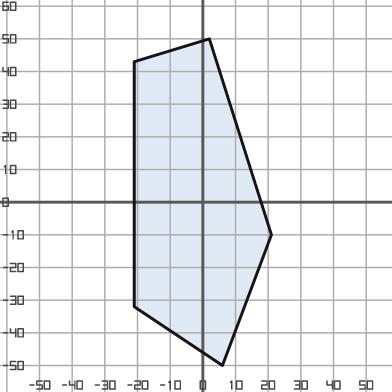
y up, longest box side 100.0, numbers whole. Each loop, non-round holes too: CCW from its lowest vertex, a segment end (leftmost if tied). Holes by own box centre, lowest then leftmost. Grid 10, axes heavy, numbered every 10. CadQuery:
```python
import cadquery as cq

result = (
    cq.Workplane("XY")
    .moveTo(6.0, -50.0)
    .lineTo(21.0, -10.0)
    .lineTo(2.0, 50.0)
    .lineTo(-21.0, 43.0)
    .lineTo(-21.0, -32.0)
    .close()
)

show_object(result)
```